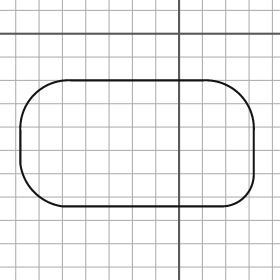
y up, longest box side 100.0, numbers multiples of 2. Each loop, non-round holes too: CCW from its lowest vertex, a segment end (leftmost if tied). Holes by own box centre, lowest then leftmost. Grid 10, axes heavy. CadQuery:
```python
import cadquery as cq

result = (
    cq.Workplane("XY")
    .moveTo(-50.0, -74.0)
    .lineTo(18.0, -74.0)
    .threePointArc((28.0, -70.0), (32.0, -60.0))
    .lineTo(32.0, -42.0)
    .threePointArc((26.0, -26.0), (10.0, -20.0))
    .lineTo(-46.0, -20.0)
    .threePointArc((-62.0, -26.0), (-68.0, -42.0))
    .lineTo(-68.0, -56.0)
    .threePointArc((-62.0, -68.0), (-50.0, -74.0))
    .close()
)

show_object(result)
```